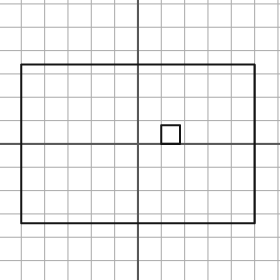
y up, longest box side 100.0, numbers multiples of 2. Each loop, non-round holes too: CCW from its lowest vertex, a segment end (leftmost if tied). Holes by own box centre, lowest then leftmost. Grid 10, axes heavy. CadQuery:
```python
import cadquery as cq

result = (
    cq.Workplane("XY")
    .moveTo(-50.0, -34.0)
    .lineTo(50.0, -34.0)
    .lineTo(50.0, 34.0)
    .lineTo(-50.0, 34.0)
    .close()
    .moveTo(10.0, 0.0)
    .lineTo(18.0, 0.0)
    .lineTo(18.0, 8.0)
    .lineTo(10.0, 8.0)
    .close()
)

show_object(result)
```